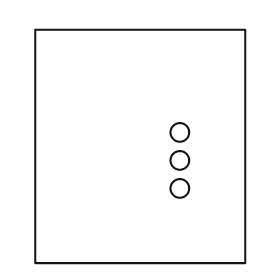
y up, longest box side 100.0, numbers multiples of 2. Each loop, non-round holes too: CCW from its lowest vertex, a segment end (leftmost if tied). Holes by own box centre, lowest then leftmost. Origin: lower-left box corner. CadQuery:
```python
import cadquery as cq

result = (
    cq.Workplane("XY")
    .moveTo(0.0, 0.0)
    .lineTo(90.0, 0.0)
    .lineTo(90.0, 100.0)
    .lineTo(0.0, 100.0)
    .close()
    .moveTo(62.0, 32.0)
    .circle(4.0)
    .moveTo(62.0, 44.0)
    .circle(4.0)
    .moveTo(62.0, 56.0)
    .circle(4.0)
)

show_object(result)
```